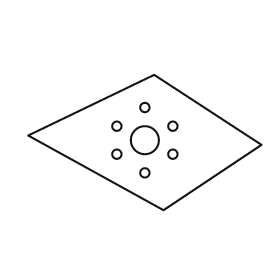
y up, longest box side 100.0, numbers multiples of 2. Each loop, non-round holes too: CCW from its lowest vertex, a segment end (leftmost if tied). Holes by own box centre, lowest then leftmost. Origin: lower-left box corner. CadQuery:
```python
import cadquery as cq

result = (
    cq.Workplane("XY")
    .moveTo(58.0, 0.0)
    .lineTo(100.0, 28.0)
    .lineTo(54.0, 58.0)
    .lineTo(0.0, 32.0)
    .close()
    .moveTo(50.0, 16.0)
    .circle(2.0)
    .moveTo(38.0, 24.0)
    .circle(2.0)
    .moveTo(62.0, 24.0)
    .circle(2.0)
    .moveTo(50.0, 30.0)
    .circle(6.0)
    .moveTo(38.0, 36.0)
    .circle(2.0)
    .moveTo(62.0, 36.0)
    .circle(2.0)
    .moveTo(50.0, 44.0)
    .circle(2.0)
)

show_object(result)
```